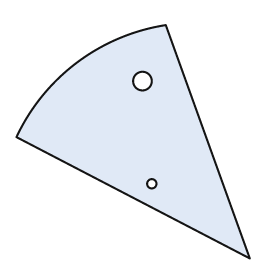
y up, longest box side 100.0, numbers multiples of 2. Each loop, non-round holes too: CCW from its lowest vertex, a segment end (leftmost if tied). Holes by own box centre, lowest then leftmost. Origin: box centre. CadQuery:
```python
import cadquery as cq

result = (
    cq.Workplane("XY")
    .moveTo(50.0, -50.0)
    .lineTo(14.0, 50.0)
    .threePointArc((-24.0, 34.0), (-50.0, 2.0))
    .close()
    .moveTo(8.0, -18.0)
    .circle(2.0)
    .moveTo(4.0, 26.0)
    .circle(4.0)
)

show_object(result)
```